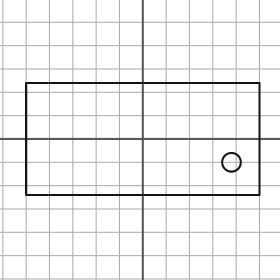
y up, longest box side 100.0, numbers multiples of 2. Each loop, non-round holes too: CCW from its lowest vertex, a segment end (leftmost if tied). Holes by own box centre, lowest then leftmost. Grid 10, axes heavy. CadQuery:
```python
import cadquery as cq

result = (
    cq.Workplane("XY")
    .moveTo(-50.0, -24.0)
    .lineTo(50.0, -24.0)
    .lineTo(50.0, 24.0)
    .lineTo(-50.0, 24.0)
    .close()
    .moveTo(38.0, -10.0)
    .circle(4.0)
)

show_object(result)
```